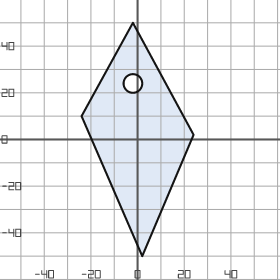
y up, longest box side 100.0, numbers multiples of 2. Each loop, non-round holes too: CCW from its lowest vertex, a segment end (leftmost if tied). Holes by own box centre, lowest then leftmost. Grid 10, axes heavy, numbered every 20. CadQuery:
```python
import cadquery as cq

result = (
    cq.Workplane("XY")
    .moveTo(2.0, -50.0)
    .lineTo(24.0, 2.0)
    .lineTo(-2.0, 50.0)
    .lineTo(-24.0, 10.0)
    .close()
    .moveTo(-2.0, 24.0)
    .circle(4.0)
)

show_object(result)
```